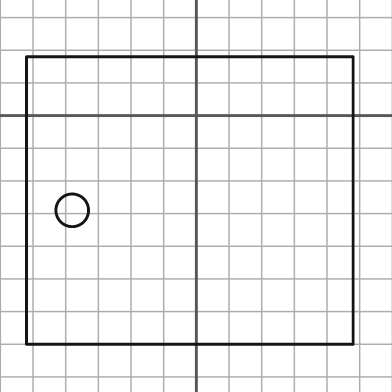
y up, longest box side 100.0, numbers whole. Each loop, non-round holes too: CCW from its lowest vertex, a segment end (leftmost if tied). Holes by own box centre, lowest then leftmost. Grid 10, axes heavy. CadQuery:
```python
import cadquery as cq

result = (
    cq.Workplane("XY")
    .moveTo(-52.0, -70.0)
    .lineTo(48.0, -70.0)
    .lineTo(48.0, 18.0)
    .lineTo(-52.0, 18.0)
    .close()
    .moveTo(-38.0, -29.0)
    .circle(5.0)
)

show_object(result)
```